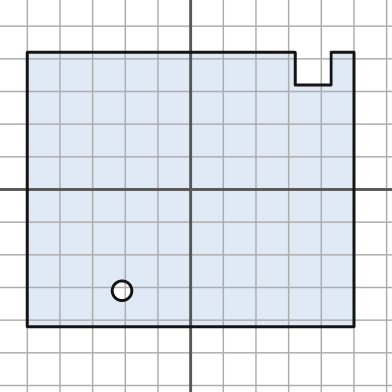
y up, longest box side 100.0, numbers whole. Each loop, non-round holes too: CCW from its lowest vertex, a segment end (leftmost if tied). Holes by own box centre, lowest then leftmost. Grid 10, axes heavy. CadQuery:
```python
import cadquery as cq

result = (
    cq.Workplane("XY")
    .moveTo(-50.0, -42.0)
    .lineTo(50.0, -42.0)
    .lineTo(50.0, 42.0)
    .lineTo(43.0, 42.0)
    .lineTo(43.0, 32.0)
    .lineTo(32.0, 32.0)
    .lineTo(32.0, 42.0)
    .lineTo(-50.0, 42.0)
    .close()
    .moveTo(-21.0, -31.0)
    .circle(3.0)
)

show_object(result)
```